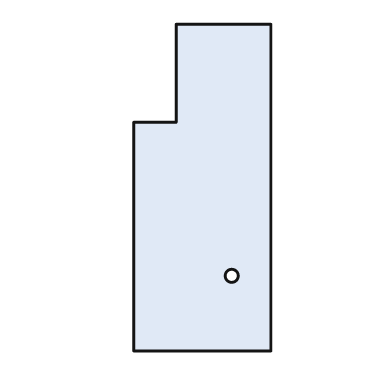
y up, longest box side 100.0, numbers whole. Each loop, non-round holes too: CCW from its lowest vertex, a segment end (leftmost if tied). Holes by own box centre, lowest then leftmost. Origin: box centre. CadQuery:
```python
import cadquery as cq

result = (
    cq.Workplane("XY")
    .moveTo(-21.0, -50.0)
    .lineTo(21.0, -50.0)
    .lineTo(21.0, 50.0)
    .lineTo(-8.0, 50.0)
    .lineTo(-8.0, 20.0)
    .lineTo(-21.0, 20.0)
    .close()
    .moveTo(9.0, -27.0)
    .circle(2.0)
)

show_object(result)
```